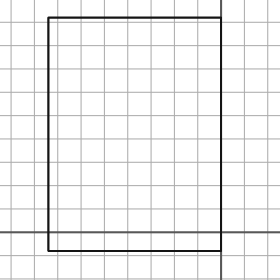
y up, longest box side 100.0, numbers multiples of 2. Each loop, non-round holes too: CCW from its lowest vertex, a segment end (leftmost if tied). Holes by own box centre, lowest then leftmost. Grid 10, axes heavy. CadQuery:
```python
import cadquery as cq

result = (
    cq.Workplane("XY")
    .moveTo(-74.0, -8.0)
    .lineTo(0.0, -8.0)
    .lineTo(0.0, 92.0)
    .lineTo(-74.0, 92.0)
    .close()
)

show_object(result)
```